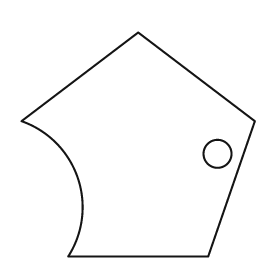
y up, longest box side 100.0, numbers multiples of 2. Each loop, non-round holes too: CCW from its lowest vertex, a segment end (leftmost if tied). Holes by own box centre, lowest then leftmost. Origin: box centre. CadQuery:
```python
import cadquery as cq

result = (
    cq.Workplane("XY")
    .moveTo(-30.0, -48.0)
    .lineTo(30.0, -48.0)
    .lineTo(50.0, 10.0)
    .lineTo(0.0, 48.0)
    .lineTo(-50.0, 10.0)
    .threePointArc((-26.0, -14.0), (-30.0, -48.0))
    .close()
    .moveTo(34.0, -4.0)
    .circle(6.0)
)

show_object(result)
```